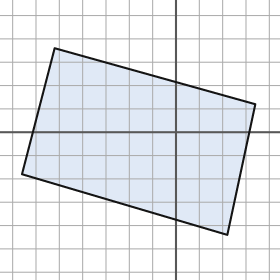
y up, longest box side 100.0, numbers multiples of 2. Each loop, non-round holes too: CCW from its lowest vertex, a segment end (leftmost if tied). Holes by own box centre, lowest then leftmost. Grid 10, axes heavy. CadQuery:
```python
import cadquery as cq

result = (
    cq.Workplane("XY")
    .moveTo(22.0, -44.0)
    .lineTo(34.0, 12.0)
    .lineTo(-52.0, 36.0)
    .lineTo(-66.0, -18.0)
    .close()
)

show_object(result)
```